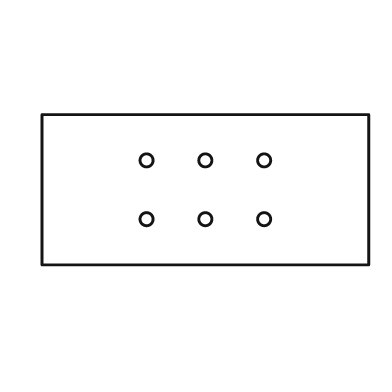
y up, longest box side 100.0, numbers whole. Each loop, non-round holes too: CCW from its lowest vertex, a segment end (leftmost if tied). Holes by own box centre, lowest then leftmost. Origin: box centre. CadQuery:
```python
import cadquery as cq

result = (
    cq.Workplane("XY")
    .moveTo(-50.0, -23.0)
    .lineTo(50.0, -23.0)
    .lineTo(50.0, 23.0)
    .lineTo(-50.0, 23.0)
    .close()
    .moveTo(-18.0, -9.0)
    .circle(2.0)
    .moveTo(0.0, -9.0)
    .circle(2.0)
    .moveTo(18.0, -9.0)
    .circle(2.0)
    .moveTo(-18.0, 9.0)
    .circle(2.0)
    .moveTo(0.0, 9.0)
    .circle(2.0)
    .moveTo(18.0, 9.0)
    .circle(2.0)
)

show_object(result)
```